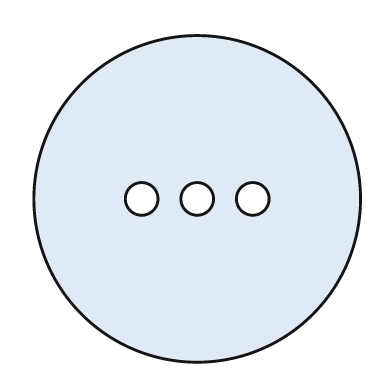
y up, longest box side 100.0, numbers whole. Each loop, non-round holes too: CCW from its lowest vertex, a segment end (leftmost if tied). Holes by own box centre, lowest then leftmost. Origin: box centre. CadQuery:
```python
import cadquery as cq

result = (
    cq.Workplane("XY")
    .moveTo(0.0, 0.0)
    .circle(50.0)
    .moveTo(-17.0, 0.0)
    .circle(5.0)
    .moveTo(0.0, 0.0)
    .circle(5.0)
    .moveTo(17.0, 0.0)
    .circle(5.0)
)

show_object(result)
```